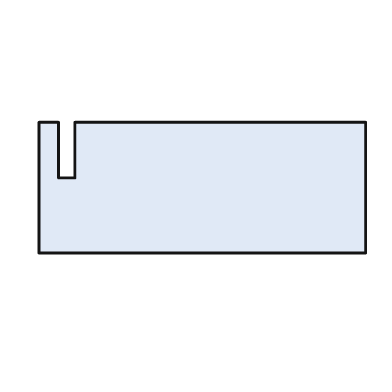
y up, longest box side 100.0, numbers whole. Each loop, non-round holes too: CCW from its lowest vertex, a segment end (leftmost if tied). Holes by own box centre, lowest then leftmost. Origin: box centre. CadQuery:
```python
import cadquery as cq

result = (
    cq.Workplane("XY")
    .moveTo(-50.0, -20.0)
    .lineTo(50.0, -20.0)
    .lineTo(50.0, 20.0)
    .lineTo(-39.0, 20.0)
    .lineTo(-39.0, 3.0)
    .lineTo(-44.0, 3.0)
    .lineTo(-44.0, 20.0)
    .lineTo(-50.0, 20.0)
    .close()
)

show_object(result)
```